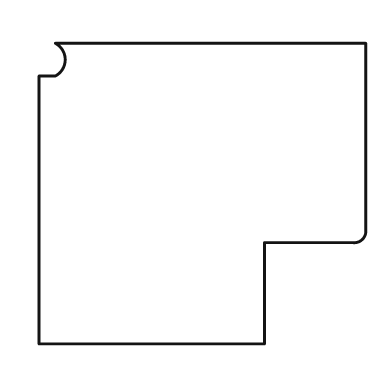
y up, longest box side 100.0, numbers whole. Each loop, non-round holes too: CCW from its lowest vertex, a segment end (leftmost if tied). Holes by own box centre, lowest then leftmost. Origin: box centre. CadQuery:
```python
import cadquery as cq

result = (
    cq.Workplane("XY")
    .moveTo(-50.0, -46.0)
    .lineTo(19.0, -46.0)
    .lineTo(19.0, -15.0)
    .lineTo(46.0, -15.0)
    .threePointArc((49.0, -14.0), (50.0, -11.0))
    .lineTo(50.0, 46.0)
    .lineTo(-45.0, 46.0)
    .threePointArc((-42.0, 41.0), (-45.0, 36.0))
    .lineTo(-50.0, 36.0)
    .close()
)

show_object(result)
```